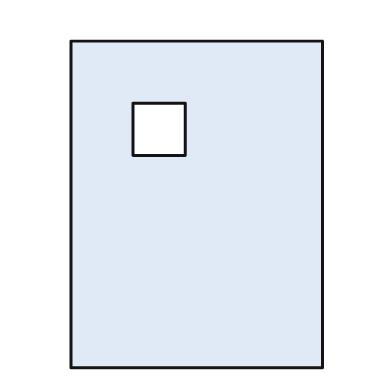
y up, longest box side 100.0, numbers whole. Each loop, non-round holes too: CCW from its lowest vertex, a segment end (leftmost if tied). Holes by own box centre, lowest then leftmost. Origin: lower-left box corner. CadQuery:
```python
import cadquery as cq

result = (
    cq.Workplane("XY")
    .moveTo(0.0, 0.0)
    .lineTo(77.0, 0.0)
    .lineTo(77.0, 100.0)
    .lineTo(0.0, 100.0)
    .close()
    .moveTo(19.0, 65.0)
    .lineTo(35.0, 65.0)
    .lineTo(35.0, 81.0)
    .lineTo(19.0, 81.0)
    .close()
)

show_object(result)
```